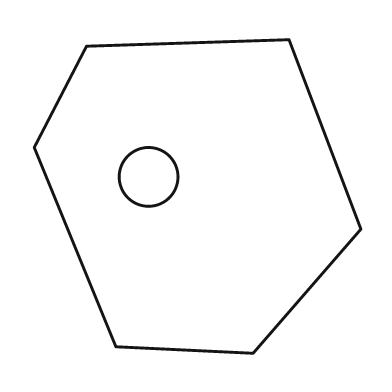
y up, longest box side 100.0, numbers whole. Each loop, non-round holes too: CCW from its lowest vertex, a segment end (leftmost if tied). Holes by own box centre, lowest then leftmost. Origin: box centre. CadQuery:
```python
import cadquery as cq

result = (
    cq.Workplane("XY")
    .moveTo(17.0, -48.0)
    .lineTo(50.0, -10.0)
    .lineTo(28.0, 48.0)
    .lineTo(-34.0, 46.0)
    .lineTo(-50.0, 15.0)
    .lineTo(-25.0, -46.0)
    .close()
    .moveTo(-15.0, 6.0)
    .circle(9.0)
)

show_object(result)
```